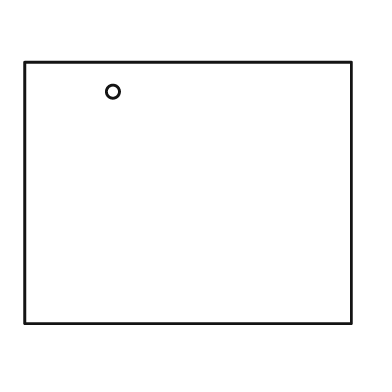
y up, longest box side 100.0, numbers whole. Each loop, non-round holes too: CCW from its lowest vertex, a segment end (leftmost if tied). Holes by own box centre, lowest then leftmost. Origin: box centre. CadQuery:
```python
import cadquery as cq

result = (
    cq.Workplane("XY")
    .moveTo(-50.0, -40.0)
    .lineTo(50.0, -40.0)
    .lineTo(50.0, 40.0)
    .lineTo(-50.0, 40.0)
    .close()
    .moveTo(-23.0, 31.0)
    .circle(2.0)
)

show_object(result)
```